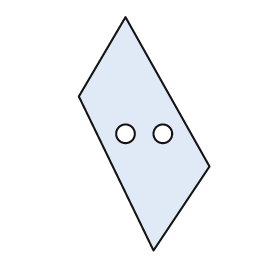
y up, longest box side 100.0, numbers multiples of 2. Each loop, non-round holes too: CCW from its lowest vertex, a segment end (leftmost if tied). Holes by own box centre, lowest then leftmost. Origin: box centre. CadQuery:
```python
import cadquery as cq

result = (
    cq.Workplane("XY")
    .moveTo(4.0, -50.0)
    .lineTo(28.0, -14.0)
    .lineTo(-8.0, 50.0)
    .lineTo(-28.0, 16.0)
    .close()
    .moveTo(-8.0, 0.0)
    .circle(4.0)
    .moveTo(8.0, 0.0)
    .circle(4.0)
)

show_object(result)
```